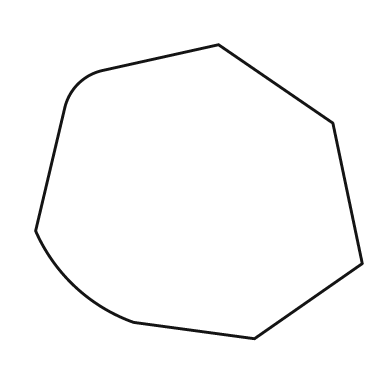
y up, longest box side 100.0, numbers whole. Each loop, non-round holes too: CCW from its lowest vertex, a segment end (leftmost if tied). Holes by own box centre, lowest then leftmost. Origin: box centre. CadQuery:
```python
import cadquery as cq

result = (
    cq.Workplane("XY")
    .moveTo(17.0, -45.0)
    .lineTo(50.0, -22.0)
    .lineTo(41.0, 21.0)
    .lineTo(6.0, 45.0)
    .lineTo(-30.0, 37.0)
    .threePointArc((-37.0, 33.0), (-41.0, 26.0))
    .lineTo(-50.0, -12.0)
    .threePointArc((-38.0, -29.0), (-20.0, -40.0))
    .close()
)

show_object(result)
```